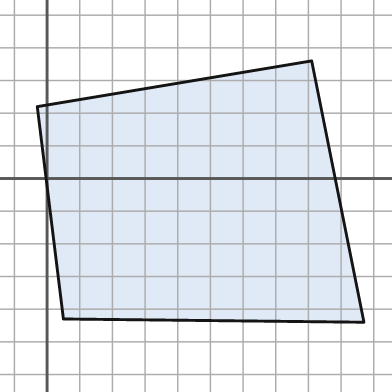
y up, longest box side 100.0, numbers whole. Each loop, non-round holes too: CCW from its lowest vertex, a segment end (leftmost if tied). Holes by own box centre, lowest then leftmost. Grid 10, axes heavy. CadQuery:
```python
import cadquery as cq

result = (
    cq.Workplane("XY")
    .moveTo(97.0, -44.0)
    .lineTo(81.0, 36.0)
    .lineTo(-3.0, 22.0)
    .lineTo(5.0, -43.0)
    .close()
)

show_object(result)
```